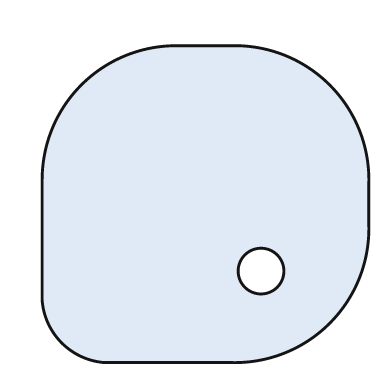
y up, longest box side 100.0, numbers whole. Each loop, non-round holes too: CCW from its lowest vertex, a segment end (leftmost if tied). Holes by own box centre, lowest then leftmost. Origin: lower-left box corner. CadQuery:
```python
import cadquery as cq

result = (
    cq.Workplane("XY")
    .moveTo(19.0, 0.0)
    .lineTo(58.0, 0.0)
    .threePointArc((88.0, 12.0), (100.0, 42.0))
    .lineTo(100.0, 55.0)
    .threePointArc((88.0, 85.0), (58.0, 97.0))
    .lineTo(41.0, 97.0)
    .threePointArc((12.0, 85.0), (0.0, 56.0))
    .lineTo(0.0, 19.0)
    .threePointArc((6.0, 6.0), (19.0, 0.0))
    .close()
    .moveTo(67.0, 28.0)
    .circle(7.0)
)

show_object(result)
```